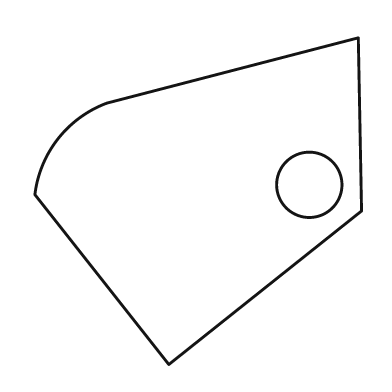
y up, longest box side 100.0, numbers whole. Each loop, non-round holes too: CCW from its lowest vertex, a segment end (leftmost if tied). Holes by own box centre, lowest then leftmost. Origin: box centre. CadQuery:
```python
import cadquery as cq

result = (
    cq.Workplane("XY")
    .moveTo(-9.0, -50.0)
    .lineTo(50.0, -3.0)
    .lineTo(49.0, 50.0)
    .lineTo(-28.0, 30.0)
    .threePointArc((-43.0, 19.0), (-50.0, 2.0))
    .close()
    .moveTo(34.0, 5.0)
    .circle(10.0)
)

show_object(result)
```